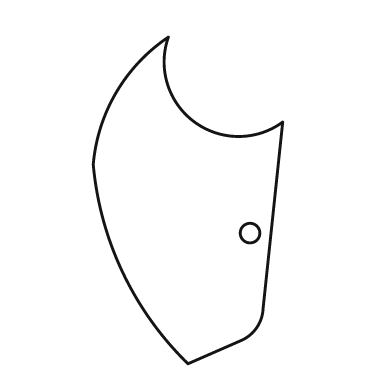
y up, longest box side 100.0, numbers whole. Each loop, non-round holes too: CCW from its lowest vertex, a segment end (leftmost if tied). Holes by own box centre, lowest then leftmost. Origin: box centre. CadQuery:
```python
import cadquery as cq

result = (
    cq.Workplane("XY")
    .moveTo(0.0, -50.0)
    .lineTo(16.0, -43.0)
    .threePointArc((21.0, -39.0), (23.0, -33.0))
    .lineTo(29.0, 24.0)
    .threePointArc((2.0, 24.0), (-6.0, 50.0))
    .threePointArc((-22.0, 33.0), (-29.0, 11.0))
    .threePointArc((-20.0, -22.0), (0.0, -50.0))
    .close()
    .moveTo(19.0, -10.0)
    .circle(3.0)
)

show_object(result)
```